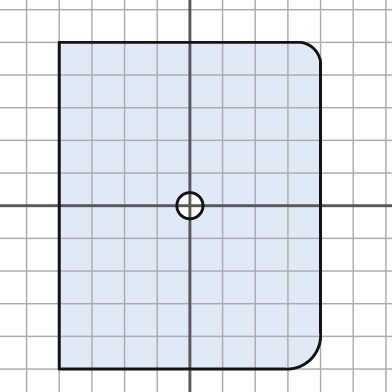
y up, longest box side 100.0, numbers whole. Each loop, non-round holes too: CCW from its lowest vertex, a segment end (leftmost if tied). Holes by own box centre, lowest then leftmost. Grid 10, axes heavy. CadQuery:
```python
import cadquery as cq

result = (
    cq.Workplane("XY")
    .moveTo(-40.0, -50.0)
    .lineTo(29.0, -50.0)
    .threePointArc((37.0, -47.0), (40.0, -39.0))
    .lineTo(40.0, 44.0)
    .threePointArc((38.0, 48.0), (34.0, 50.0))
    .lineTo(-40.0, 50.0)
    .close()
    .moveTo(0.0, 0.0)
    .circle(4.0)
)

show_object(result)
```